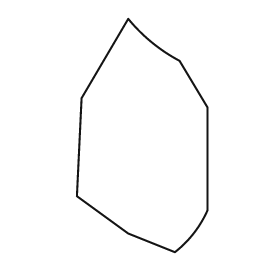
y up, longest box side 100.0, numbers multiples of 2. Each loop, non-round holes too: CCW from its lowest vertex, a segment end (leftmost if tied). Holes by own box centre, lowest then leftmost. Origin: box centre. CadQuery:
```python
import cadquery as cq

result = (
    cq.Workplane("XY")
    .moveTo(14.0, -50.0)
    .threePointArc((22.0, -42.0), (28.0, -32.0))
    .lineTo(28.0, 12.0)
    .lineTo(16.0, 32.0)
    .threePointArc((4.0, 40.0), (-6.0, 50.0))
    .lineTo(-26.0, 16.0)
    .lineTo(-28.0, -26.0)
    .lineTo(-6.0, -42.0)
    .close()
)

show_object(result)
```